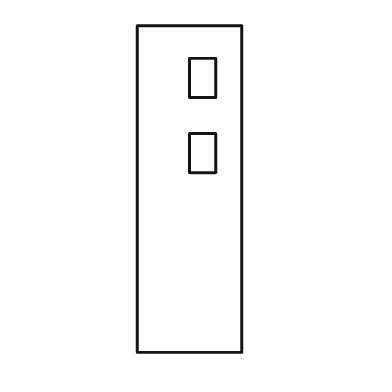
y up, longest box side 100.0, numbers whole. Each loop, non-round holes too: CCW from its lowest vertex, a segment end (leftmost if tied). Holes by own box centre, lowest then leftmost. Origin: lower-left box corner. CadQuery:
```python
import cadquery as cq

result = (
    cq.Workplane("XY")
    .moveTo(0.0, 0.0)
    .lineTo(32.0, 0.0)
    .lineTo(32.0, 100.0)
    .lineTo(0.0, 100.0)
    .close()
    .moveTo(16.0, 55.0)
    .lineTo(24.0, 55.0)
    .lineTo(24.0, 67.0)
    .lineTo(16.0, 67.0)
    .close()
    .moveTo(16.0, 78.0)
    .lineTo(24.0, 78.0)
    .lineTo(24.0, 90.0)
    .lineTo(16.0, 90.0)
    .close()
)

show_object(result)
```